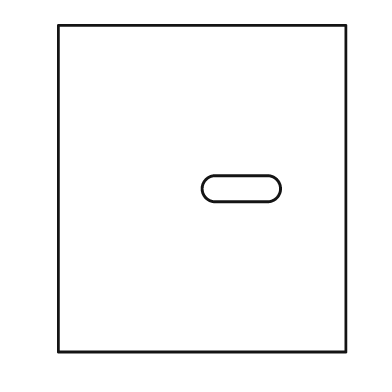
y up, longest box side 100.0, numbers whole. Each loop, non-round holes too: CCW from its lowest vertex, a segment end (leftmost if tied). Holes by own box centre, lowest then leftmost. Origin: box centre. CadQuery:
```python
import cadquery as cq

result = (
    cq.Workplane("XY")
    .moveTo(-44.0, -50.0)
    .lineTo(44.0, -50.0)
    .lineTo(44.0, 50.0)
    .lineTo(-44.0, 50.0)
    .close()
    .moveTo(4.0, -4.0)
    .lineTo(20.0, -4.0)
    .threePointArc((24.0, 0.0), (20.0, 4.0))
    .lineTo(4.0, 4.0)
    .threePointArc((0.0, 0.0), (4.0, -4.0))
    .close()
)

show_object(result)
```